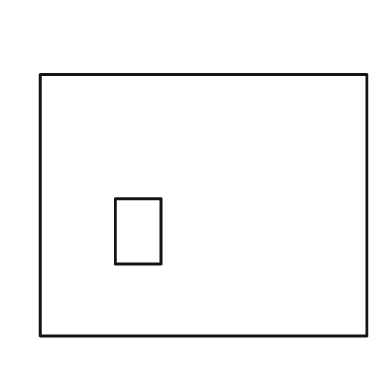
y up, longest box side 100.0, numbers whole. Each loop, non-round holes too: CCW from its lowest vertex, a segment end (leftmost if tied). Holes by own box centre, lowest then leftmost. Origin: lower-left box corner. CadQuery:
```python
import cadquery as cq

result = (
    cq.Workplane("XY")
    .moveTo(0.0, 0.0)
    .lineTo(100.0, 0.0)
    .lineTo(100.0, 80.0)
    .lineTo(0.0, 80.0)
    .close()
    .moveTo(23.0, 22.0)
    .lineTo(37.0, 22.0)
    .lineTo(37.0, 42.0)
    .lineTo(23.0, 42.0)
    .close()
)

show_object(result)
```